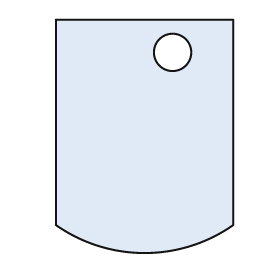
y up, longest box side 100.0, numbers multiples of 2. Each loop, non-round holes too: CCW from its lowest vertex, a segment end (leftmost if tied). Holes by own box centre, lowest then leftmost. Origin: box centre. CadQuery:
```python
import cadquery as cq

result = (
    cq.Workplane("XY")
    .moveTo(-38.0, -38.0)
    .threePointArc((0.0, -50.0), (38.0, -38.0))
    .lineTo(38.0, 50.0)
    .lineTo(-38.0, 50.0)
    .close()
    .moveTo(12.0, 36.0)
    .circle(8.0)
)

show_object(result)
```